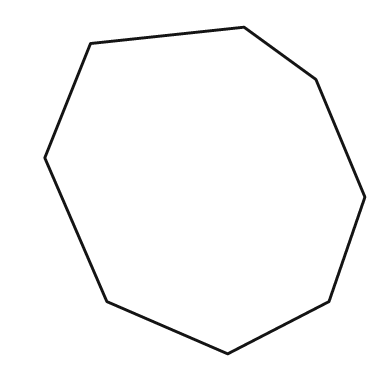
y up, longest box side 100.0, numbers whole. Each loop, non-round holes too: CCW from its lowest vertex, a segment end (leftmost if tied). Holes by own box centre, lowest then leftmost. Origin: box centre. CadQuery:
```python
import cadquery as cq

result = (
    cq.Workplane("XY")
    .moveTo(7.0, -50.0)
    .lineTo(38.0, -34.0)
    .lineTo(49.0, -2.0)
    .lineTo(34.0, 34.0)
    .lineTo(12.0, 50.0)
    .lineTo(-35.0, 45.0)
    .lineTo(-49.0, 10.0)
    .lineTo(-30.0, -34.0)
    .close()
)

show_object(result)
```